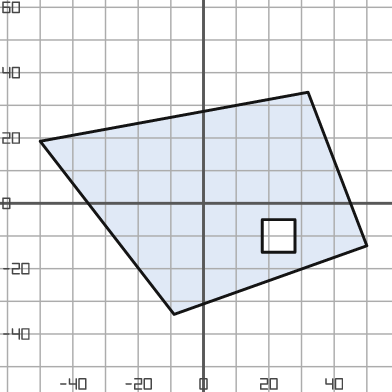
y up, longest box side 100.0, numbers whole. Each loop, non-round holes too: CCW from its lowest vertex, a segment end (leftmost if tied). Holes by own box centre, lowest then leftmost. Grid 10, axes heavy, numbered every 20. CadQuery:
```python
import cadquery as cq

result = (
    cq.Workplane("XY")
    .moveTo(-9.0, -34.0)
    .lineTo(50.0, -13.0)
    .lineTo(32.0, 34.0)
    .lineTo(-50.0, 19.0)
    .close()
    .moveTo(18.0, -15.0)
    .lineTo(28.0, -15.0)
    .lineTo(28.0, -5.0)
    .lineTo(18.0, -5.0)
    .close()
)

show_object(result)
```